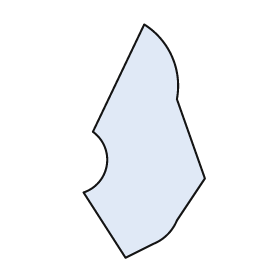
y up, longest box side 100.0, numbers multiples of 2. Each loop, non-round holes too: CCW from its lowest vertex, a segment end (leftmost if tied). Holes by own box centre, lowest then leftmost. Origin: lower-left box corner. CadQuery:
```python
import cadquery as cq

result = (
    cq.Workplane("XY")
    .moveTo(18.0, 0.0)
    .lineTo(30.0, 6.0)
    .threePointArc((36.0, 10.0), (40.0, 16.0))
    .lineTo(52.0, 34.0)
    .lineTo(40.0, 68.0)
    .threePointArc((38.0, 86.0), (26.0, 100.0))
    .lineTo(4.0, 54.0)
    .threePointArc((10.0, 40.0), (0.0, 28.0))
    .close()
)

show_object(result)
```